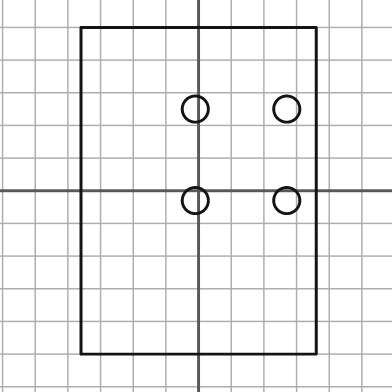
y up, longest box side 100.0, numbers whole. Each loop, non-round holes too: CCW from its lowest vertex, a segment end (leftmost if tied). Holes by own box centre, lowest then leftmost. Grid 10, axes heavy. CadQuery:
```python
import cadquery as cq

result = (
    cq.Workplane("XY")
    .moveTo(-36.0, -50.0)
    .lineTo(36.0, -50.0)
    .lineTo(36.0, 50.0)
    .lineTo(-36.0, 50.0)
    .close()
    .moveTo(-1.0, -3.0)
    .circle(4.0)
    .moveTo(27.0, -3.0)
    .circle(4.0)
    .moveTo(-1.0, 25.0)
    .circle(4.0)
    .moveTo(27.0, 25.0)
    .circle(4.0)
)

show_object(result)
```